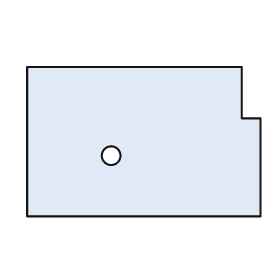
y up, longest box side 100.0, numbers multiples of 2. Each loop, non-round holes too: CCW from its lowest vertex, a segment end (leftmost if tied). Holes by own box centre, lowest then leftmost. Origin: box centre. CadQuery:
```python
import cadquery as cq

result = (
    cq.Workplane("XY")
    .moveTo(-50.0, -32.0)
    .lineTo(50.0, -32.0)
    .lineTo(50.0, 10.0)
    .lineTo(42.0, 10.0)
    .lineTo(42.0, 32.0)
    .lineTo(-50.0, 32.0)
    .close()
    .moveTo(-14.0, -6.0)
    .circle(4.0)
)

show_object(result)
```